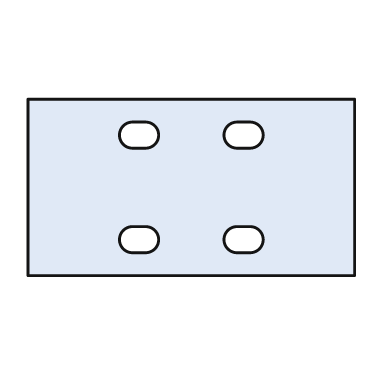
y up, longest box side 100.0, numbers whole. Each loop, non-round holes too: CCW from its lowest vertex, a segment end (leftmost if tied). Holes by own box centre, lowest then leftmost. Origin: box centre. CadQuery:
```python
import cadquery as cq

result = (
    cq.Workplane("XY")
    .moveTo(-50.0, -27.0)
    .lineTo(50.0, -27.0)
    .lineTo(50.0, 27.0)
    .lineTo(-50.0, 27.0)
    .close()
    .moveTo(-18.0, -20.0)
    .lineTo(-14.0, -20.0)
    .threePointArc((-10.0, -16.0), (-14.0, -12.0))
    .lineTo(-18.0, -12.0)
    .threePointArc((-22.0, -16.0), (-18.0, -20.0))
    .close()
    .moveTo(14.0, -20.0)
    .lineTo(18.0, -20.0)
    .threePointArc((22.0, -16.0), (18.0, -12.0))
    .lineTo(14.0, -12.0)
    .threePointArc((10.0, -16.0), (14.0, -20.0))
    .close()
    .moveTo(-18.0, 12.0)
    .lineTo(-14.0, 12.0)
    .threePointArc((-10.0, 16.0), (-14.0, 20.0))
    .lineTo(-18.0, 20.0)
    .threePointArc((-22.0, 16.0), (-18.0, 12.0))
    .close()
    .moveTo(14.0, 12.0)
    .lineTo(18.0, 12.0)
    .threePointArc((22.0, 16.0), (18.0, 20.0))
    .lineTo(14.0, 20.0)
    .threePointArc((10.0, 16.0), (14.0, 12.0))
    .close()
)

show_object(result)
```